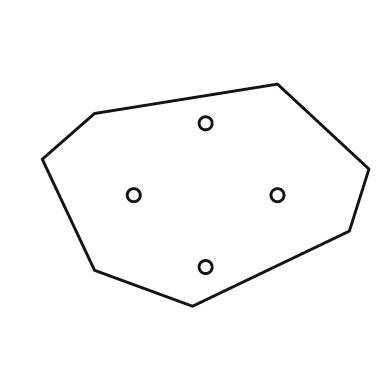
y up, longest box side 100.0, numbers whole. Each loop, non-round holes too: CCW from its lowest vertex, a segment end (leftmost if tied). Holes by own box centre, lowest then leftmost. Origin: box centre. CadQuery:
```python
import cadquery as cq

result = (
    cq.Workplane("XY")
    .moveTo(-4.0, -34.0)
    .lineTo(44.0, -11.0)
    .lineTo(50.0, 8.0)
    .lineTo(22.0, 34.0)
    .lineTo(-34.0, 25.0)
    .lineTo(-50.0, 11.0)
    .lineTo(-34.0, -23.0)
    .close()
    .moveTo(0.0, -22.0)
    .circle(2.0)
    .moveTo(-22.0, 0.0)
    .circle(2.0)
    .moveTo(22.0, 0.0)
    .circle(2.0)
    .moveTo(0.0, 22.0)
    .circle(2.0)
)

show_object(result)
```